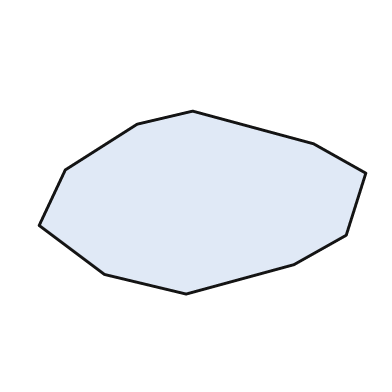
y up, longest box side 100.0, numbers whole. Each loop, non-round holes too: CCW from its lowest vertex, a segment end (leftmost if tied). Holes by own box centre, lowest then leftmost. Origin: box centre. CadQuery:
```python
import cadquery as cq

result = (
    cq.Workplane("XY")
    .moveTo(-5.0, -28.0)
    .lineTo(28.0, -19.0)
    .lineTo(44.0, -10.0)
    .lineTo(50.0, 9.0)
    .lineTo(34.0, 18.0)
    .lineTo(-3.0, 28.0)
    .lineTo(-20.0, 24.0)
    .lineTo(-42.0, 10.0)
    .lineTo(-50.0, -7.0)
    .lineTo(-30.0, -22.0)
    .close()
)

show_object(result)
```